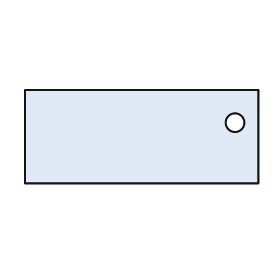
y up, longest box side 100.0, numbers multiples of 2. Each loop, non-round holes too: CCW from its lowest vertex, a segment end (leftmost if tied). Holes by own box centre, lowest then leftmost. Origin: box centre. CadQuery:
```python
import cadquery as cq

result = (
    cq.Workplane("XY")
    .moveTo(-50.0, -20.0)
    .lineTo(50.0, -20.0)
    .lineTo(50.0, 20.0)
    .lineTo(-50.0, 20.0)
    .close()
    .moveTo(40.0, 6.0)
    .circle(4.0)
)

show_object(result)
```